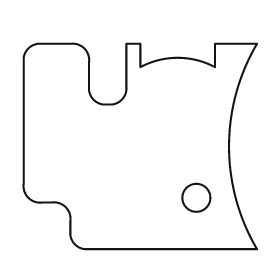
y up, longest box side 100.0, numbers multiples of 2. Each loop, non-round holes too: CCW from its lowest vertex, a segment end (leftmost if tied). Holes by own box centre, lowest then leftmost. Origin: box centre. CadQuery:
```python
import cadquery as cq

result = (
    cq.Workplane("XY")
    .moveTo(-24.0, -44.0)
    .lineTo(50.0, -44.0)
    .threePointArc((38.0, 0.0), (50.0, 44.0))
    .lineTo(32.0, 44.0)
    .lineTo(32.0, 34.0)
    .threePointArc((16.0, 38.0), (0.0, 34.0))
    .lineTo(0.0, 44.0)
    .lineTo(-6.0, 44.0)
    .lineTo(-6.0, 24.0)
    .threePointArc((-8.0, 20.0), (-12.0, 18.0))
    .lineTo(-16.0, 18.0)
    .threePointArc((-20.0, 20.0), (-22.0, 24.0))
    .lineTo(-22.0, 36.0)
    .threePointArc((-24.0, 42.0), (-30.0, 44.0))
    .lineTo(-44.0, 44.0)
    .threePointArc((-48.0, 42.0), (-50.0, 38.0))
    .lineTo(-50.0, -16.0)
    .threePointArc((-48.0, -22.0), (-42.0, -24.0))
    .lineTo(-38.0, -24.0)
    .threePointArc((-32.0, -26.0), (-30.0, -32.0))
    .lineTo(-30.0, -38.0)
    .threePointArc((-28.0, -42.0), (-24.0, -44.0))
    .close()
    .moveTo(24.0, -22.0)
    .circle(6.0)
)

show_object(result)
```